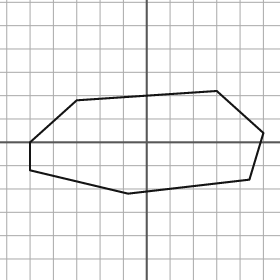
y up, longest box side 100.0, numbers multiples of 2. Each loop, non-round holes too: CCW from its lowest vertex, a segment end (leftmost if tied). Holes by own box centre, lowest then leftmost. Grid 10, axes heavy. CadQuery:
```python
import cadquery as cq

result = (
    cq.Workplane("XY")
    .moveTo(-8.0, -22.0)
    .lineTo(44.0, -16.0)
    .lineTo(50.0, 4.0)
    .lineTo(30.0, 22.0)
    .lineTo(-30.0, 18.0)
    .lineTo(-50.0, 0.0)
    .lineTo(-50.0, -12.0)
    .close()
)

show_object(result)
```